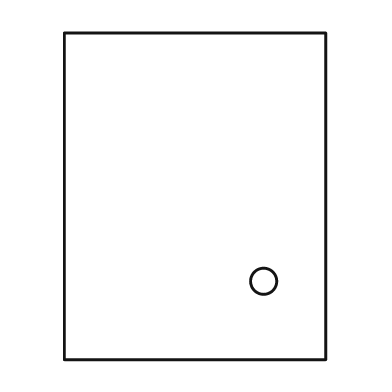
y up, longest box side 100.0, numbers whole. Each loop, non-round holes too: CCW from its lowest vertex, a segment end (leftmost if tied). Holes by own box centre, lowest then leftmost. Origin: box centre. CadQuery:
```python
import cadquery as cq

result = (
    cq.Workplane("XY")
    .moveTo(-40.0, -50.0)
    .lineTo(40.0, -50.0)
    .lineTo(40.0, 50.0)
    .lineTo(-40.0, 50.0)
    .close()
    .moveTo(21.0, -26.0)
    .circle(4.0)
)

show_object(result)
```